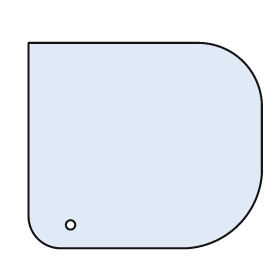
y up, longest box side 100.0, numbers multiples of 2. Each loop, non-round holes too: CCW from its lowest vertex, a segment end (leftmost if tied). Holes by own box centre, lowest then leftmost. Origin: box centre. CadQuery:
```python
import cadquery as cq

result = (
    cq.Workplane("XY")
    .moveTo(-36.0, -44.0)
    .lineTo(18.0, -44.0)
    .threePointArc((40.0, -34.0), (50.0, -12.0))
    .lineTo(50.0, 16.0)
    .threePointArc((42.0, 36.0), (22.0, 44.0))
    .lineTo(-50.0, 44.0)
    .lineTo(-50.0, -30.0)
    .threePointArc((-46.0, -40.0), (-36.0, -44.0))
    .close()
    .moveTo(-32.0, -34.0)
    .circle(2.0)
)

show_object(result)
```